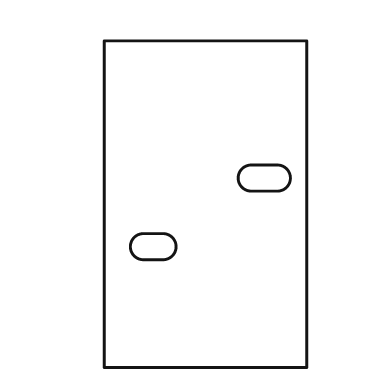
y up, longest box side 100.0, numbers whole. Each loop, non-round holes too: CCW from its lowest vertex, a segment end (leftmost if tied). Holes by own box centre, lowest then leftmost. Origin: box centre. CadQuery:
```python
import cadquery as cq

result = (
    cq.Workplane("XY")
    .moveTo(-31.0, -50.0)
    .lineTo(31.0, -50.0)
    .lineTo(31.0, 50.0)
    .lineTo(-31.0, 50.0)
    .close()
    .moveTo(-19.0, -17.0)
    .lineTo(-13.0, -17.0)
    .threePointArc((-9.0, -13.0), (-13.0, -9.0))
    .lineTo(-19.0, -9.0)
    .threePointArc((-23.0, -13.0), (-19.0, -17.0))
    .close()
    .moveTo(14.0, 4.0)
    .lineTo(22.0, 4.0)
    .threePointArc((26.0, 8.0), (22.0, 12.0))
    .lineTo(14.0, 12.0)
    .threePointArc((10.0, 8.0), (14.0, 4.0))
    .close()
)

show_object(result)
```